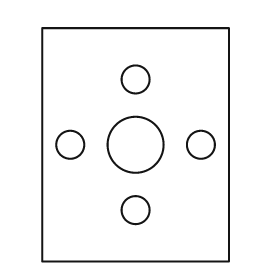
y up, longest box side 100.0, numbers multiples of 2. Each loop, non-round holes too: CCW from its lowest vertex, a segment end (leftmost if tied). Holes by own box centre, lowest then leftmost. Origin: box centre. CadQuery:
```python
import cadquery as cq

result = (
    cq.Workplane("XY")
    .moveTo(-40.0, -50.0)
    .lineTo(40.0, -50.0)
    .lineTo(40.0, 50.0)
    .lineTo(-40.0, 50.0)
    .close()
    .moveTo(0.0, -28.0)
    .circle(6.0)
    .moveTo(-28.0, 0.0)
    .circle(6.0)
    .moveTo(0.0, 0.0)
    .circle(12.0)
    .moveTo(28.0, 0.0)
    .circle(6.0)
    .moveTo(0.0, 28.0)
    .circle(6.0)
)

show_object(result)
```